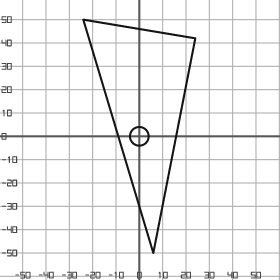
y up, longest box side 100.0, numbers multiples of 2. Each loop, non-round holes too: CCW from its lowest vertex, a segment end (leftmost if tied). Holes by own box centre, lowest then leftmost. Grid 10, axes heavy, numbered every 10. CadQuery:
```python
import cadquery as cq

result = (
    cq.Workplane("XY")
    .moveTo(6.0, -50.0)
    .lineTo(24.0, 42.0)
    .lineTo(-24.0, 50.0)
    .close()
    .moveTo(0.0, 0.0)
    .circle(4.0)
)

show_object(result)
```